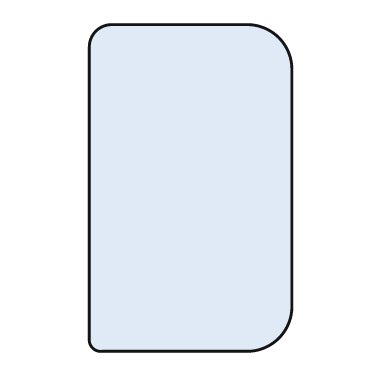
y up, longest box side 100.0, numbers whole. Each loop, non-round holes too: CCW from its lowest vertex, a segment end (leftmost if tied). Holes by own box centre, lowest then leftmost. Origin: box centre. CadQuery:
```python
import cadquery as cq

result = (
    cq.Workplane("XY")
    .moveTo(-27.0, -50.0)
    .lineTo(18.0, -50.0)
    .threePointArc((27.0, -46.0), (31.0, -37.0))
    .lineTo(31.0, 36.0)
    .threePointArc((27.0, 46.0), (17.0, 50.0))
    .lineTo(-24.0, 50.0)
    .threePointArc((-29.0, 48.0), (-31.0, 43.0))
    .lineTo(-31.0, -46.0)
    .threePointArc((-30.0, -49.0), (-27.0, -50.0))
    .close()
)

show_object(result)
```